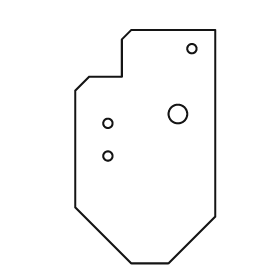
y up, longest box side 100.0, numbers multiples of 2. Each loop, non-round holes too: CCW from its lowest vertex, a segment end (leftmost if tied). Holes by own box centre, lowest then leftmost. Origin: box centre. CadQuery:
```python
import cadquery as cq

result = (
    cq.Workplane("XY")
    .moveTo(-6.0, -50.0)
    .lineTo(10.0, -50.0)
    .lineTo(30.0, -30.0)
    .lineTo(30.0, 50.0)
    .lineTo(-6.0, 50.0)
    .lineTo(-10.0, 46.0)
    .lineTo(-10.0, 30.0)
    .lineTo(-24.0, 30.0)
    .lineTo(-30.0, 24.0)
    .lineTo(-30.0, -26.0)
    .close()
    .moveTo(-16.0, -4.0)
    .circle(2.0)
    .moveTo(-16.0, 10.0)
    .circle(2.0)
    .moveTo(14.0, 14.0)
    .circle(4.0)
    .moveTo(20.0, 42.0)
    .circle(2.0)
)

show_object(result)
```